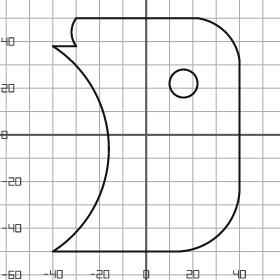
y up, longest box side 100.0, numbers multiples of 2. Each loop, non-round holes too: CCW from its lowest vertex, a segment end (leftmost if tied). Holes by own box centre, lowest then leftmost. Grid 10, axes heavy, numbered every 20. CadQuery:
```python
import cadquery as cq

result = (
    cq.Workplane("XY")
    .moveTo(-40.0, -50.0)
    .lineTo(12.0, -50.0)
    .threePointArc((32.0, -42.0), (40.0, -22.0))
    .lineTo(40.0, 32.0)
    .threePointArc((34.0, 44.0), (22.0, 50.0))
    .lineTo(-30.0, 50.0)
    .threePointArc((-32.0, 44.0), (-30.0, 38.0))
    .lineTo(-40.0, 38.0)
    .threePointArc((-16.0, -6.0), (-40.0, -50.0))
    .close()
    .moveTo(16.0, 22.0)
    .circle(6.0)
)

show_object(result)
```